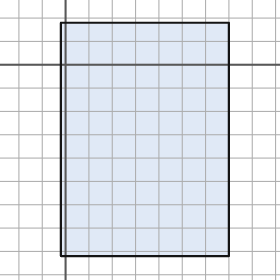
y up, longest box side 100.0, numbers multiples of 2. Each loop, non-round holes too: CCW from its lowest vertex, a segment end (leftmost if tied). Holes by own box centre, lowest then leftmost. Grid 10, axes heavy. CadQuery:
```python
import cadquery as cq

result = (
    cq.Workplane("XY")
    .moveTo(-2.0, -82.0)
    .lineTo(70.0, -82.0)
    .lineTo(70.0, 18.0)
    .lineTo(-2.0, 18.0)
    .close()
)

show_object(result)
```